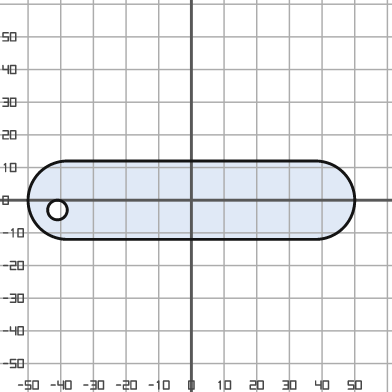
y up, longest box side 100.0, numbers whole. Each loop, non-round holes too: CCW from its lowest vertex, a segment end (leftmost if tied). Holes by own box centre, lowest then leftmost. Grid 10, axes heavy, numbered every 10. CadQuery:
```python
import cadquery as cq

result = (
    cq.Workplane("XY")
    .moveTo(-38.0, -12.0)
    .lineTo(38.0, -12.0)
    .threePointArc((50.0, 0.0), (38.0, 12.0))
    .lineTo(-38.0, 12.0)
    .threePointArc((-50.0, 0.0), (-38.0, -12.0))
    .close()
    .moveTo(-41.0, -3.0)
    .circle(3.0)
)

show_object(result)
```